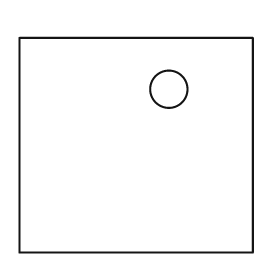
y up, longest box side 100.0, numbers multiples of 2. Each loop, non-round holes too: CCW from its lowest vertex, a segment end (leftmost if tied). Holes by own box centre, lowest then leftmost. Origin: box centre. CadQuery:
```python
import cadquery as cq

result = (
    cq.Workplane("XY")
    .moveTo(-50.0, -46.0)
    .lineTo(50.0, -46.0)
    .lineTo(50.0, 46.0)
    .lineTo(-50.0, 46.0)
    .close()
    .moveTo(14.0, 24.0)
    .circle(8.0)
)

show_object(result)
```